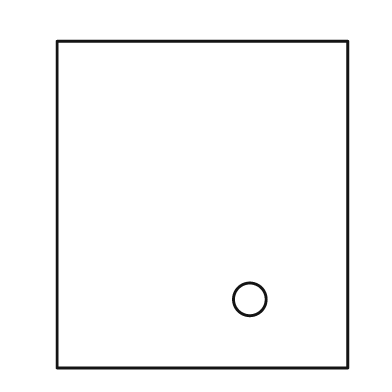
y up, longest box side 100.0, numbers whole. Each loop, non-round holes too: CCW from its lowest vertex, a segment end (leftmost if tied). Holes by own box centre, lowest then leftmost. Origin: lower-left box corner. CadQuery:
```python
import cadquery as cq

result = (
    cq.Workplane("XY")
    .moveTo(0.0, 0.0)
    .lineTo(89.0, 0.0)
    .lineTo(89.0, 100.0)
    .lineTo(0.0, 100.0)
    .close()
    .moveTo(59.0, 21.0)
    .circle(5.0)
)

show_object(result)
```